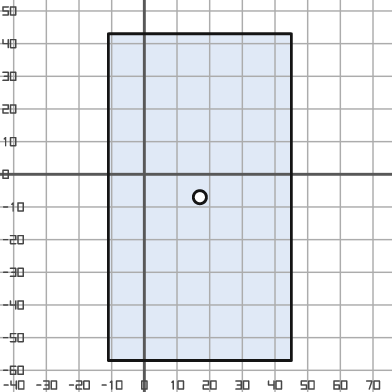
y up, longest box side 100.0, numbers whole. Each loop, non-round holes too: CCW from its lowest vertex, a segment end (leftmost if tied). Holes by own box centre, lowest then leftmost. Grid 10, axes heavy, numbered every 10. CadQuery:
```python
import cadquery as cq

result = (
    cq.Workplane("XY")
    .moveTo(-11.0, -57.0)
    .lineTo(45.0, -57.0)
    .lineTo(45.0, 43.0)
    .lineTo(-11.0, 43.0)
    .close()
    .moveTo(17.0, -7.0)
    .circle(2.0)
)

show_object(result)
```